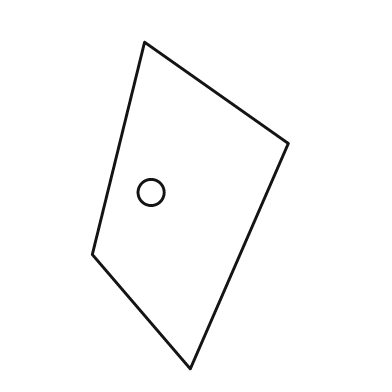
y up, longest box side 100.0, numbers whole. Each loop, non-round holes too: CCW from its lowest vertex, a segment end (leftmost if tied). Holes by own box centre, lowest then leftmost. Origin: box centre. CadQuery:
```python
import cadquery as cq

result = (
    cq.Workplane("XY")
    .moveTo(0.0, -50.0)
    .lineTo(30.0, 19.0)
    .lineTo(-14.0, 50.0)
    .lineTo(-30.0, -15.0)
    .close()
    .moveTo(-12.0, 4.0)
    .circle(4.0)
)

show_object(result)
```